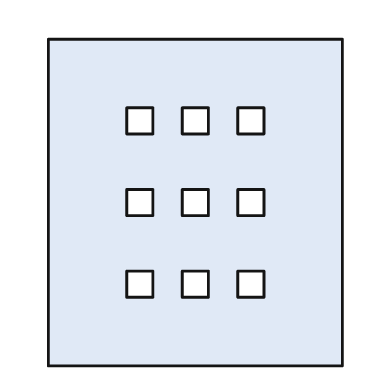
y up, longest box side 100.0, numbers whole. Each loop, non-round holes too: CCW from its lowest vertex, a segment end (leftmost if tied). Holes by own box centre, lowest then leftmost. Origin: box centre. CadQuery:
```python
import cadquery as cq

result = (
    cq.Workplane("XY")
    .moveTo(-45.0, -50.0)
    .lineTo(45.0, -50.0)
    .lineTo(45.0, 50.0)
    .lineTo(-45.0, 50.0)
    .close()
    .moveTo(-21.0, -29.0)
    .lineTo(-13.0, -29.0)
    .lineTo(-13.0, -21.0)
    .lineTo(-21.0, -21.0)
    .close()
    .moveTo(-4.0, -29.0)
    .lineTo(4.0, -29.0)
    .lineTo(4.0, -21.0)
    .lineTo(-4.0, -21.0)
    .close()
    .moveTo(13.0, -29.0)
    .lineTo(21.0, -29.0)
    .lineTo(21.0, -21.0)
    .lineTo(13.0, -21.0)
    .close()
    .moveTo(-21.0, -4.0)
    .lineTo(-13.0, -4.0)
    .lineTo(-13.0, 4.0)
    .lineTo(-21.0, 4.0)
    .close()
    .moveTo(-4.0, -4.0)
    .lineTo(4.0, -4.0)
    .lineTo(4.0, 4.0)
    .lineTo(-4.0, 4.0)
    .close()
    .moveTo(13.0, -4.0)
    .lineTo(21.0, -4.0)
    .lineTo(21.0, 4.0)
    .lineTo(13.0, 4.0)
    .close()
    .moveTo(-21.0, 21.0)
    .lineTo(-13.0, 21.0)
    .lineTo(-13.0, 29.0)
    .lineTo(-21.0, 29.0)
    .close()
    .moveTo(-4.0, 21.0)
    .lineTo(4.0, 21.0)
    .lineTo(4.0, 29.0)
    .lineTo(-4.0, 29.0)
    .close()
    .moveTo(13.0, 21.0)
    .lineTo(21.0, 21.0)
    .lineTo(21.0, 29.0)
    .lineTo(13.0, 29.0)
    .close()
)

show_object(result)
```